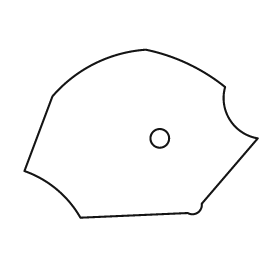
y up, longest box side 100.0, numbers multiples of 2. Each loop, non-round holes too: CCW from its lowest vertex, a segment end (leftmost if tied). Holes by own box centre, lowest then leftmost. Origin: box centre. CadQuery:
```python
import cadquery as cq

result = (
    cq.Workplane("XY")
    .moveTo(-26.0, -36.0)
    .lineTo(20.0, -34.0)
    .threePointArc((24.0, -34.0), (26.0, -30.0))
    .lineTo(50.0, -2.0)
    .threePointArc((38.0, 6.0), (36.0, 20.0))
    .threePointArc((20.0, 30.0), (2.0, 36.0))
    .threePointArc((-20.0, 30.0), (-38.0, 16.0))
    .lineTo(-50.0, -16.0)
    .threePointArc((-36.0, -24.0), (-26.0, -36.0))
    .close()
    .moveTo(8.0, -2.0)
    .circle(4.0)
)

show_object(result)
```